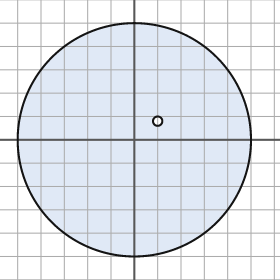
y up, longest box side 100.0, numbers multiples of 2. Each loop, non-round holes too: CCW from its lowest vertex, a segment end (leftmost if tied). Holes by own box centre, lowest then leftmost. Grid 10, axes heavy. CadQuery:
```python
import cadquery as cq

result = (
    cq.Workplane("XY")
    .moveTo(0.0, 0.0)
    .circle(50.0)
    .moveTo(10.0, 8.0)
    .circle(2.0)
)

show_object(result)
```